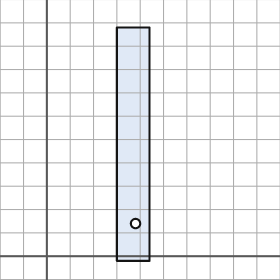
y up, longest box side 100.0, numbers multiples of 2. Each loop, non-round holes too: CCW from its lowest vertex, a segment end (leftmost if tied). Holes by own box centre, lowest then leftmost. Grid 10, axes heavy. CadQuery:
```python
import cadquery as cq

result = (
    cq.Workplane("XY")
    .moveTo(30.0, -2.0)
    .lineTo(44.0, -2.0)
    .lineTo(44.0, 98.0)
    .lineTo(30.0, 98.0)
    .close()
    .moveTo(38.0, 14.0)
    .circle(2.0)
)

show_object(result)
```